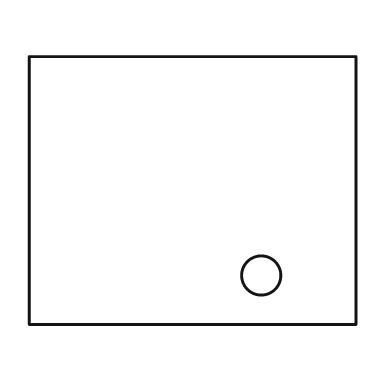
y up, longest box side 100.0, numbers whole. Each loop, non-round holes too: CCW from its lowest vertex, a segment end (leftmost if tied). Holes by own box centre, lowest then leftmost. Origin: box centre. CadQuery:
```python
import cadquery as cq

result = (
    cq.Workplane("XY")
    .moveTo(-50.0, -41.0)
    .lineTo(50.0, -41.0)
    .lineTo(50.0, 41.0)
    .lineTo(-50.0, 41.0)
    .close()
    .moveTo(21.0, -26.0)
    .circle(6.0)
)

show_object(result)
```